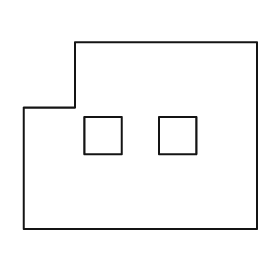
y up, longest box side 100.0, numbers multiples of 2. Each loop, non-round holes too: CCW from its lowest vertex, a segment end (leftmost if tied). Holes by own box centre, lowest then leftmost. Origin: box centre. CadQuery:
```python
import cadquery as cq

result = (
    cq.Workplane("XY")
    .moveTo(-50.0, -40.0)
    .lineTo(50.0, -40.0)
    .lineTo(50.0, 40.0)
    .lineTo(-28.0, 40.0)
    .lineTo(-28.0, 12.0)
    .lineTo(-50.0, 12.0)
    .close()
    .moveTo(-24.0, -8.0)
    .lineTo(-8.0, -8.0)
    .lineTo(-8.0, 8.0)
    .lineTo(-24.0, 8.0)
    .close()
    .moveTo(8.0, -8.0)
    .lineTo(24.0, -8.0)
    .lineTo(24.0, 8.0)
    .lineTo(8.0, 8.0)
    .close()
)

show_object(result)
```